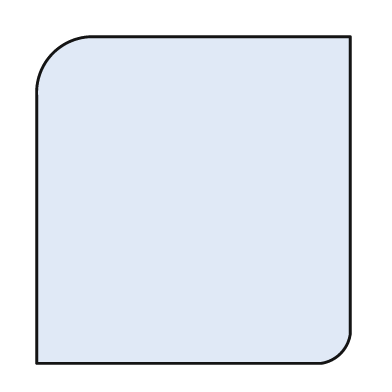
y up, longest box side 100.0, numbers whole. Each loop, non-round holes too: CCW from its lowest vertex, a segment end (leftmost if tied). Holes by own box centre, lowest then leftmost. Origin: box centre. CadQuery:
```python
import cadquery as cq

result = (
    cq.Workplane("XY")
    .moveTo(-48.0, -50.0)
    .lineTo(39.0, -50.0)
    .threePointArc((45.0, -47.0), (48.0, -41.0))
    .lineTo(48.0, 50.0)
    .lineTo(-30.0, 50.0)
    .threePointArc((-43.0, 45.0), (-48.0, 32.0))
    .close()
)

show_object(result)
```